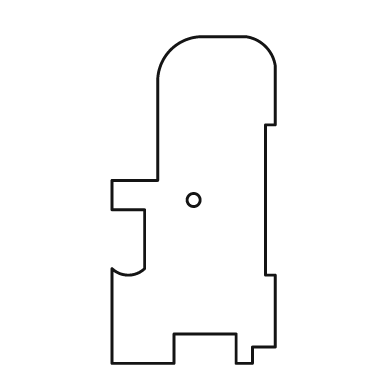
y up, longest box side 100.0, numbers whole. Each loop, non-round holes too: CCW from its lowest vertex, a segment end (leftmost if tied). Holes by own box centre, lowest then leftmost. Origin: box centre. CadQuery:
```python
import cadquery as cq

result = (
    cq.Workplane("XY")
    .moveTo(-25.0, -50.0)
    .lineTo(-6.0, -50.0)
    .lineTo(-6.0, -41.0)
    .lineTo(13.0, -41.0)
    .lineTo(13.0, -50.0)
    .lineTo(18.0, -50.0)
    .lineTo(18.0, -45.0)
    .lineTo(25.0, -45.0)
    .lineTo(25.0, -23.0)
    .lineTo(22.0, -23.0)
    .lineTo(22.0, 23.0)
    .lineTo(25.0, 23.0)
    .lineTo(25.0, 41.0)
    .threePointArc((22.0, 47.0), (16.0, 50.0))
    .lineTo(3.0, 50.0)
    .threePointArc((-7.0, 46.0), (-11.0, 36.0))
    .lineTo(-11.0, 6.0)
    .lineTo(-25.0, 6.0)
    .lineTo(-25.0, -3.0)
    .lineTo(-15.0, -3.0)
    .lineTo(-15.0, -21.0)
    .threePointArc((-20.0, -23.0), (-25.0, -21.0))
    .close()
    .moveTo(0.0, 0.0)
    .circle(2.0)
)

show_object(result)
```